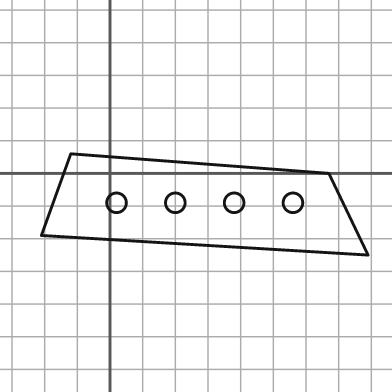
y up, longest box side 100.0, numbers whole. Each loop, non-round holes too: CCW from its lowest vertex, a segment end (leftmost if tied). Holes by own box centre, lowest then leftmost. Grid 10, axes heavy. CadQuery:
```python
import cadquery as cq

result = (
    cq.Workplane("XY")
    .moveTo(79.0, -25.0)
    .lineTo(67.0, 0.0)
    .lineTo(-12.0, 6.0)
    .lineTo(-21.0, -19.0)
    .close()
    .moveTo(2.0, -9.0)
    .circle(3.0)
    .moveTo(20.0, -9.0)
    .circle(3.0)
    .moveTo(38.0, -9.0)
    .circle(3.0)
    .moveTo(56.0, -9.0)
    .circle(3.0)
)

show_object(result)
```